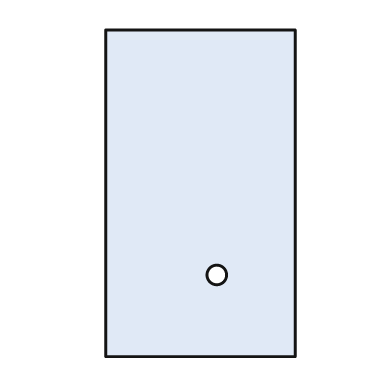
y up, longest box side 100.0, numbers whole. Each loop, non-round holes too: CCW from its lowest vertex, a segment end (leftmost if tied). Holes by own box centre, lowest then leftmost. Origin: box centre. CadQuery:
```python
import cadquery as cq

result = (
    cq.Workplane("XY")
    .moveTo(-29.0, -50.0)
    .lineTo(29.0, -50.0)
    .lineTo(29.0, 50.0)
    .lineTo(-29.0, 50.0)
    .close()
    .moveTo(5.0, -25.0)
    .circle(3.0)
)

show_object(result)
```